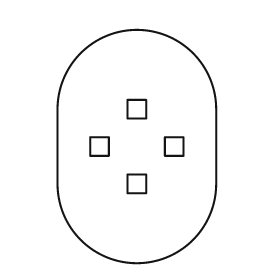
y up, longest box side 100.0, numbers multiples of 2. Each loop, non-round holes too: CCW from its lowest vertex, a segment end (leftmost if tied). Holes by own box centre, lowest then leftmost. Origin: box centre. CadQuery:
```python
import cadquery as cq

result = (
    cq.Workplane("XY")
    .moveTo(-34.0, -16.0)
    .threePointArc((0.0, -50.0), (34.0, -16.0))
    .lineTo(34.0, 16.0)
    .threePointArc((0.0, 50.0), (-34.0, 16.0))
    .close()
    .moveTo(-4.0, -20.0)
    .lineTo(4.0, -20.0)
    .lineTo(4.0, -12.0)
    .lineTo(-4.0, -12.0)
    .close()
    .moveTo(-20.0, -4.0)
    .lineTo(-12.0, -4.0)
    .lineTo(-12.0, 4.0)
    .lineTo(-20.0, 4.0)
    .close()
    .moveTo(12.0, -4.0)
    .lineTo(20.0, -4.0)
    .lineTo(20.0, 4.0)
    .lineTo(12.0, 4.0)
    .close()
    .moveTo(-4.0, 12.0)
    .lineTo(4.0, 12.0)
    .lineTo(4.0, 20.0)
    .lineTo(-4.0, 20.0)
    .close()
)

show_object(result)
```